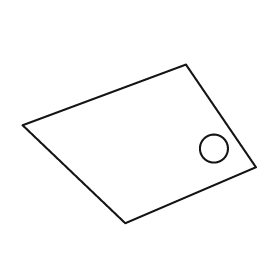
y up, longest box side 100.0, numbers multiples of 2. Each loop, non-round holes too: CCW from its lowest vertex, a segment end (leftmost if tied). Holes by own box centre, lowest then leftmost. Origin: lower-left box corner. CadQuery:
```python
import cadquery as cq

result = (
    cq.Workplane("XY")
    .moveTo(44.0, 0.0)
    .lineTo(100.0, 24.0)
    .lineTo(70.0, 68.0)
    .lineTo(0.0, 42.0)
    .close()
    .moveTo(82.0, 32.0)
    .circle(6.0)
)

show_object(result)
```